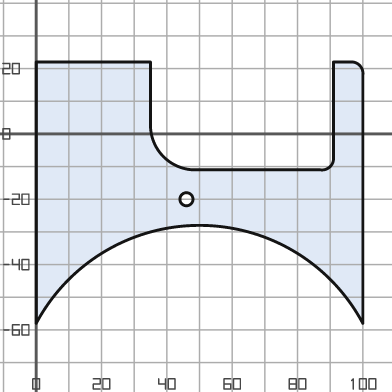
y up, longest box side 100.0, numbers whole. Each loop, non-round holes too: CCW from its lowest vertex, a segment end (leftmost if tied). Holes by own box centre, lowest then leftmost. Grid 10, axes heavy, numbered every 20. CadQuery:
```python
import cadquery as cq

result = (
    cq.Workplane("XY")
    .moveTo(0.0, -58.0)
    .threePointArc((50.0, -28.0), (100.0, -58.0))
    .lineTo(100.0, 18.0)
    .threePointArc((99.0, 21.0), (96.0, 22.0))
    .lineTo(91.0, 22.0)
    .lineTo(91.0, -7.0)
    .threePointArc((90.0, -10.0), (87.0, -11.0))
    .lineTo(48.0, -11.0)
    .threePointArc((39.0, -7.0), (35.0, 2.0))
    .lineTo(35.0, 22.0)
    .lineTo(0.0, 22.0)
    .close()
    .moveTo(46.0, -20.0)
    .circle(2.0)
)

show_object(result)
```